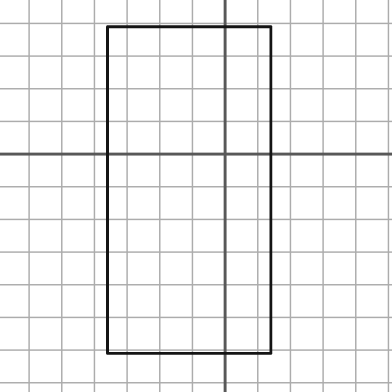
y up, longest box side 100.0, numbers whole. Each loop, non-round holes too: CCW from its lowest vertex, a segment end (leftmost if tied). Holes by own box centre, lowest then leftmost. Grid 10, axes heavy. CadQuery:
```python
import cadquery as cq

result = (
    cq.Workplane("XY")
    .moveTo(-36.0, -61.0)
    .lineTo(14.0, -61.0)
    .lineTo(14.0, 39.0)
    .lineTo(-36.0, 39.0)
    .close()
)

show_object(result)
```